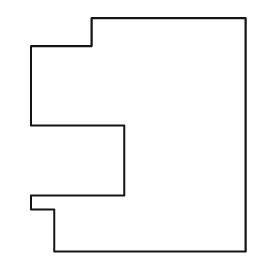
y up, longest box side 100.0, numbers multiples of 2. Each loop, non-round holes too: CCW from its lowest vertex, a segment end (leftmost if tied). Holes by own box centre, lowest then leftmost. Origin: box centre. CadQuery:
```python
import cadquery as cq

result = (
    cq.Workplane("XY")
    .moveTo(-36.0, -50.0)
    .lineTo(46.0, -50.0)
    .lineTo(46.0, 50.0)
    .lineTo(-20.0, 50.0)
    .lineTo(-20.0, 38.0)
    .lineTo(-46.0, 38.0)
    .lineTo(-46.0, 4.0)
    .lineTo(-6.0, 4.0)
    .lineTo(-6.0, -26.0)
    .lineTo(-46.0, -26.0)
    .lineTo(-46.0, -32.0)
    .lineTo(-36.0, -32.0)
    .close()
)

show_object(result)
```